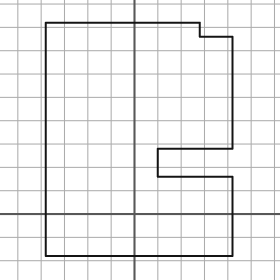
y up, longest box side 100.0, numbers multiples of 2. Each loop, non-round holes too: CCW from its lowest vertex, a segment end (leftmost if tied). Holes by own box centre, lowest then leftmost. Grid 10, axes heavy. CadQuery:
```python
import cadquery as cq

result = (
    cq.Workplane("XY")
    .moveTo(-38.0, -18.0)
    .lineTo(42.0, -18.0)
    .lineTo(42.0, 16.0)
    .lineTo(10.0, 16.0)
    .lineTo(10.0, 28.0)
    .lineTo(42.0, 28.0)
    .lineTo(42.0, 76.0)
    .lineTo(28.0, 76.0)
    .lineTo(28.0, 82.0)
    .lineTo(-38.0, 82.0)
    .close()
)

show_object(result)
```